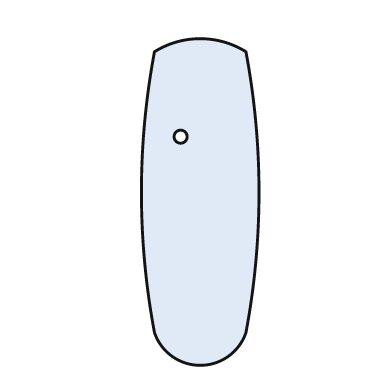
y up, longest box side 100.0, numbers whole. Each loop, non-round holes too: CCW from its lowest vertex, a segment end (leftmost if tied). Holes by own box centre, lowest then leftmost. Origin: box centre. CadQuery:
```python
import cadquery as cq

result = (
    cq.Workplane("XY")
    .moveTo(-14.0, -40.0)
    .threePointArc((0.0, -50.0), (14.0, -40.0))
    .threePointArc((18.0, 3.0), (14.0, 46.0))
    .threePointArc((0.0, 50.0), (-14.0, 46.0))
    .threePointArc((-18.0, 3.0), (-14.0, -40.0))
    .close()
    .moveTo(-6.0, 20.0)
    .circle(2.0)
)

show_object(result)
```